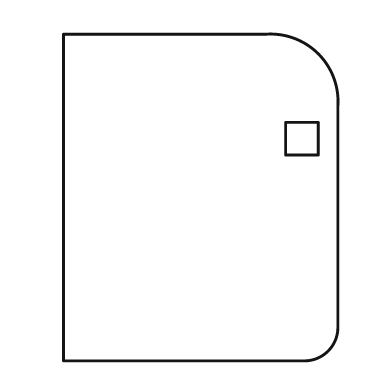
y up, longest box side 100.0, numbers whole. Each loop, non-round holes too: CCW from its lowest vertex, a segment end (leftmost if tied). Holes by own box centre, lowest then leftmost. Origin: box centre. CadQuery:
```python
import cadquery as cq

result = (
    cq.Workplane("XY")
    .moveTo(-42.0, -50.0)
    .lineTo(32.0, -50.0)
    .threePointArc((39.0, -47.0), (42.0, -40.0))
    .lineTo(42.0, 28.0)
    .threePointArc((36.0, 44.0), (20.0, 50.0))
    .lineTo(-42.0, 50.0)
    .close()
    .moveTo(26.0, 13.0)
    .lineTo(36.0, 13.0)
    .lineTo(36.0, 23.0)
    .lineTo(26.0, 23.0)
    .close()
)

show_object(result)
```